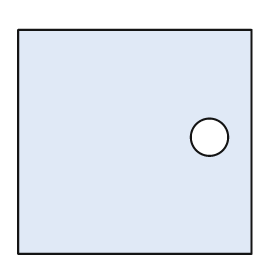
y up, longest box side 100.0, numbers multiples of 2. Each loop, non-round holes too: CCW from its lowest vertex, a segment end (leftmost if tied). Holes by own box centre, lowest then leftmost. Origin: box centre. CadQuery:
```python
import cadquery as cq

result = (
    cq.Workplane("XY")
    .moveTo(-50.0, -48.0)
    .lineTo(50.0, -48.0)
    .lineTo(50.0, 48.0)
    .lineTo(-50.0, 48.0)
    .close()
    .moveTo(32.0, 2.0)
    .circle(8.0)
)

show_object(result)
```